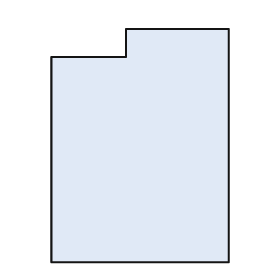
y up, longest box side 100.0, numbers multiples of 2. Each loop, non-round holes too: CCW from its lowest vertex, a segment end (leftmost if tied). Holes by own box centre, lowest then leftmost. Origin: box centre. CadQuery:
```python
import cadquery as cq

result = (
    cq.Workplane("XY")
    .moveTo(-38.0, -50.0)
    .lineTo(38.0, -50.0)
    .lineTo(38.0, 50.0)
    .lineTo(-6.0, 50.0)
    .lineTo(-6.0, 38.0)
    .lineTo(-38.0, 38.0)
    .close()
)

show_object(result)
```